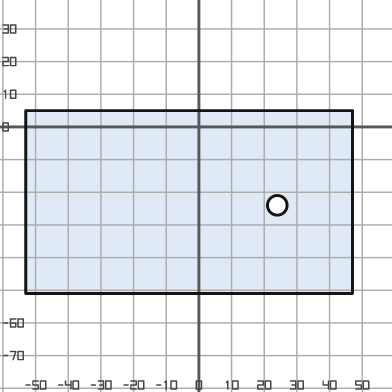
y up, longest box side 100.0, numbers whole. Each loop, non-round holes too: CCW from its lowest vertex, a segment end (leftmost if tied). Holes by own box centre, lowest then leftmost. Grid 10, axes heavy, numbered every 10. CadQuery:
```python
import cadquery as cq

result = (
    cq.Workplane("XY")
    .moveTo(-53.0, -51.0)
    .lineTo(47.0, -51.0)
    .lineTo(47.0, 5.0)
    .lineTo(-53.0, 5.0)
    .close()
    .moveTo(24.0, -24.0)
    .circle(3.0)
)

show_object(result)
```